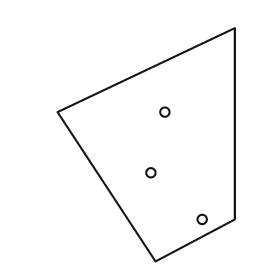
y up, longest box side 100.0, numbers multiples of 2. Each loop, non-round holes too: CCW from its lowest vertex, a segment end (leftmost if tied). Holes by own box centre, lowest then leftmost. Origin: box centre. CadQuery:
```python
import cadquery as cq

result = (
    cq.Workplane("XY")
    .moveTo(4.0, -50.0)
    .lineTo(38.0, -32.0)
    .lineTo(38.0, 50.0)
    .lineTo(-38.0, 14.0)
    .close()
    .moveTo(24.0, -32.0)
    .circle(2.0)
    .moveTo(2.0, -12.0)
    .circle(2.0)
    .moveTo(8.0, 14.0)
    .circle(2.0)
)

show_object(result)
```